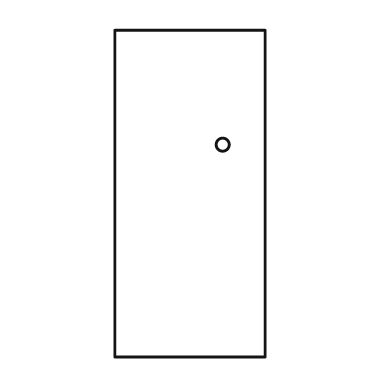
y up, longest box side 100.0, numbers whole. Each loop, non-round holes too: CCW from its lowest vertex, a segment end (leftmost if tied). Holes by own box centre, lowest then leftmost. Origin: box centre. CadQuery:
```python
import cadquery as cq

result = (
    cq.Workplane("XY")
    .moveTo(-23.0, -50.0)
    .lineTo(23.0, -50.0)
    .lineTo(23.0, 50.0)
    .lineTo(-23.0, 50.0)
    .close()
    .moveTo(10.0, 15.0)
    .circle(2.0)
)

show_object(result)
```